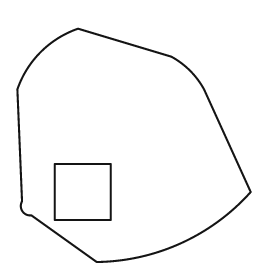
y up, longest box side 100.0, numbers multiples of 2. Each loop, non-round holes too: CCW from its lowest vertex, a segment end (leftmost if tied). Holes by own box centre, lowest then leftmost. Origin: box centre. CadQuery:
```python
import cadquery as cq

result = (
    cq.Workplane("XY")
    .moveTo(-16.0, -50.0)
    .threePointArc((20.0, -42.0), (50.0, -20.0))
    .lineTo(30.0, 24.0)
    .threePointArc((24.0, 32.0), (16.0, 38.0))
    .lineTo(-24.0, 50.0)
    .threePointArc((-40.0, 40.0), (-50.0, 24.0))
    .lineTo(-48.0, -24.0)
    .threePointArc((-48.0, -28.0), (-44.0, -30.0))
    .close()
    .moveTo(-34.0, -32.0)
    .lineTo(-10.0, -32.0)
    .lineTo(-10.0, -8.0)
    .lineTo(-34.0, -8.0)
    .close()
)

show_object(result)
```